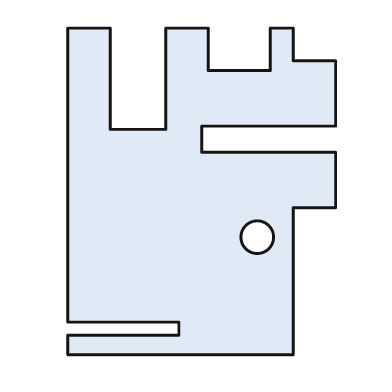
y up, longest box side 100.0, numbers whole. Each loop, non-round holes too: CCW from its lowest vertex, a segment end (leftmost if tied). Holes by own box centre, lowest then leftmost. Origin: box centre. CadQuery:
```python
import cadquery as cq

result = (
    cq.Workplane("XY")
    .moveTo(-41.0, -50.0)
    .lineTo(28.0, -50.0)
    .lineTo(28.0, -5.0)
    .lineTo(41.0, -5.0)
    .lineTo(41.0, 12.0)
    .lineTo(0.0, 12.0)
    .lineTo(0.0, 20.0)
    .lineTo(41.0, 20.0)
    .lineTo(41.0, 40.0)
    .lineTo(28.0, 40.0)
    .lineTo(28.0, 50.0)
    .lineTo(21.0, 50.0)
    .lineTo(21.0, 37.0)
    .lineTo(2.0, 37.0)
    .lineTo(2.0, 50.0)
    .lineTo(-11.0, 50.0)
    .lineTo(-11.0, 19.0)
    .lineTo(-28.0, 19.0)
    .lineTo(-28.0, 50.0)
    .lineTo(-41.0, 50.0)
    .lineTo(-41.0, -40.0)
    .lineTo(-7.0, -40.0)
    .lineTo(-7.0, -44.0)
    .lineTo(-41.0, -44.0)
    .close()
    .moveTo(17.0, -14.0)
    .circle(5.0)
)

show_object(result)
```